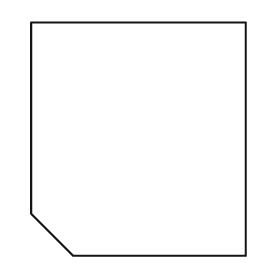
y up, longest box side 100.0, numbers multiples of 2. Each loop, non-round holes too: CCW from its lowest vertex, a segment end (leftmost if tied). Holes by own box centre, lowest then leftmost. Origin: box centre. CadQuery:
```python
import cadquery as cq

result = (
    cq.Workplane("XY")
    .moveTo(-28.0, -50.0)
    .lineTo(46.0, -50.0)
    .lineTo(46.0, 50.0)
    .lineTo(-46.0, 50.0)
    .lineTo(-46.0, -32.0)
    .close()
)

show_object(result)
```